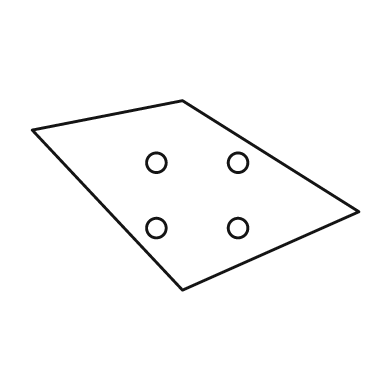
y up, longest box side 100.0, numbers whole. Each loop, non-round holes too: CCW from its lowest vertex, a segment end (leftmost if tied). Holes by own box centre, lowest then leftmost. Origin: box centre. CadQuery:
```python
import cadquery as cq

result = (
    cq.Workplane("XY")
    .moveTo(-4.0, -29.0)
    .lineTo(50.0, -5.0)
    .lineTo(-4.0, 29.0)
    .lineTo(-50.0, 20.0)
    .close()
    .moveTo(-12.0, -10.0)
    .circle(3.0)
    .moveTo(13.0, -10.0)
    .circle(3.0)
    .moveTo(-12.0, 10.0)
    .circle(3.0)
    .moveTo(13.0, 10.0)
    .circle(3.0)
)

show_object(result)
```